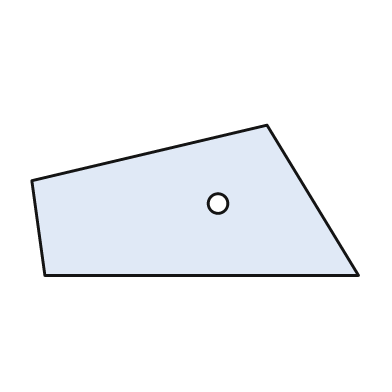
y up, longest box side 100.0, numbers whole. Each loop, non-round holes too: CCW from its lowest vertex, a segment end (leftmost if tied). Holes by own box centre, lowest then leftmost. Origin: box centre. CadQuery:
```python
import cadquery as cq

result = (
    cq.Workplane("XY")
    .moveTo(-46.0, -23.0)
    .lineTo(50.0, -23.0)
    .lineTo(22.0, 23.0)
    .lineTo(-50.0, 6.0)
    .close()
    .moveTo(7.0, -1.0)
    .circle(3.0)
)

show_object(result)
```